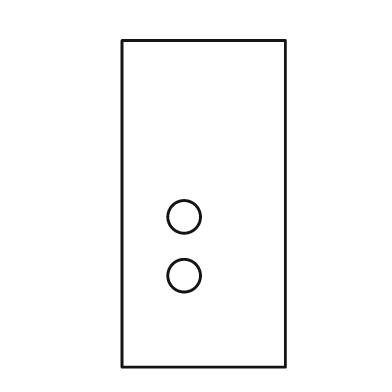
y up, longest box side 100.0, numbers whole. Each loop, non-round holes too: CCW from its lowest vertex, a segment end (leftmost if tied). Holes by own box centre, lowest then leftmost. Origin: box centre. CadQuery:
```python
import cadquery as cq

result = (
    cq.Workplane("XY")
    .moveTo(-25.0, -50.0)
    .lineTo(25.0, -50.0)
    .lineTo(25.0, 50.0)
    .lineTo(-25.0, 50.0)
    .close()
    .moveTo(-6.0, -22.0)
    .circle(5.0)
    .moveTo(-6.0, -4.0)
    .circle(5.0)
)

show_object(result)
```